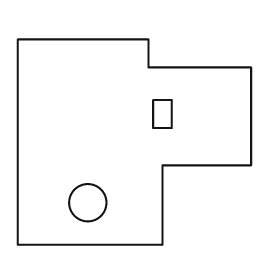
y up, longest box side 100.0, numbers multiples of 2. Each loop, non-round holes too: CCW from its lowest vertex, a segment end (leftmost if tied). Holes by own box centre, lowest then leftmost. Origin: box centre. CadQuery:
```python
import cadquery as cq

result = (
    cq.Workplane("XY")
    .moveTo(-50.0, -44.0)
    .lineTo(12.0, -44.0)
    .lineTo(12.0, -10.0)
    .lineTo(50.0, -10.0)
    .lineTo(50.0, 32.0)
    .lineTo(6.0, 32.0)
    .lineTo(6.0, 44.0)
    .lineTo(-50.0, 44.0)
    .close()
    .moveTo(-20.0, -26.0)
    .circle(8.0)
    .moveTo(8.0, 6.0)
    .lineTo(16.0, 6.0)
    .lineTo(16.0, 18.0)
    .lineTo(8.0, 18.0)
    .close()
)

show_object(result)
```